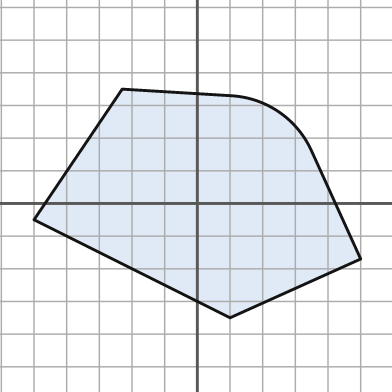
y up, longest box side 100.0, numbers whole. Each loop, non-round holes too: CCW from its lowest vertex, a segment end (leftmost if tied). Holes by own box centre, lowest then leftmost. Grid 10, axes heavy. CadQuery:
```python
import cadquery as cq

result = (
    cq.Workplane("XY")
    .moveTo(10.0, -35.0)
    .lineTo(50.0, -17.0)
    .lineTo(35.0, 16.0)
    .threePointArc((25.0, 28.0), (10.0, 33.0))
    .lineTo(-23.0, 35.0)
    .lineTo(-50.0, -5.0)
    .close()
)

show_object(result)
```